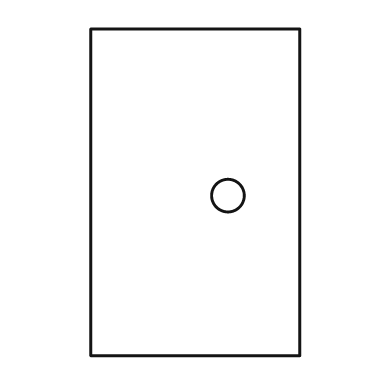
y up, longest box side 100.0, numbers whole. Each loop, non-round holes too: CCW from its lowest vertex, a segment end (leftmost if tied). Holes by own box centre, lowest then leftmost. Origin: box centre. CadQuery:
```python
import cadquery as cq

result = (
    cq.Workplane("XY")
    .moveTo(-32.0, -50.0)
    .lineTo(32.0, -50.0)
    .lineTo(32.0, 50.0)
    .lineTo(-32.0, 50.0)
    .close()
    .moveTo(10.0, -1.0)
    .circle(5.0)
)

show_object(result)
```